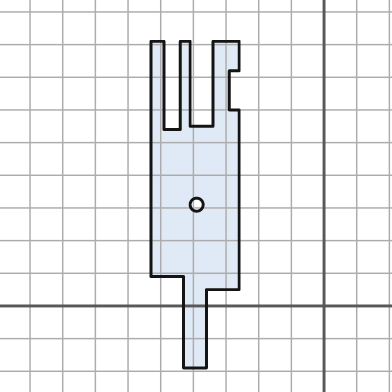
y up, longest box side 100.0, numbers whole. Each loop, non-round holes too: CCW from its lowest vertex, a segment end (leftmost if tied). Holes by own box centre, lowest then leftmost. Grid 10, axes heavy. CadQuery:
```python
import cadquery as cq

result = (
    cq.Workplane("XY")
    .moveTo(-43.0, -19.0)
    .lineTo(-36.0, -19.0)
    .lineTo(-36.0, 5.0)
    .lineTo(-26.0, 5.0)
    .lineTo(-26.0, 60.0)
    .lineTo(-29.0, 60.0)
    .lineTo(-29.0, 72.0)
    .lineTo(-26.0, 72.0)
    .lineTo(-26.0, 81.0)
    .lineTo(-34.0, 81.0)
    .lineTo(-34.0, 55.0)
    .lineTo(-41.0, 55.0)
    .lineTo(-41.0, 81.0)
    .lineTo(-44.0, 81.0)
    .lineTo(-44.0, 54.0)
    .lineTo(-49.0, 54.0)
    .lineTo(-49.0, 81.0)
    .lineTo(-53.0, 81.0)
    .lineTo(-53.0, 9.0)
    .lineTo(-43.0, 9.0)
    .close()
    .moveTo(-39.0, 31.0)
    .circle(2.0)
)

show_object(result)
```